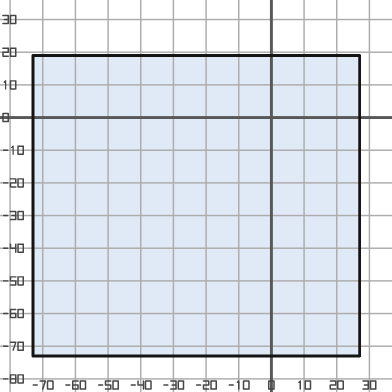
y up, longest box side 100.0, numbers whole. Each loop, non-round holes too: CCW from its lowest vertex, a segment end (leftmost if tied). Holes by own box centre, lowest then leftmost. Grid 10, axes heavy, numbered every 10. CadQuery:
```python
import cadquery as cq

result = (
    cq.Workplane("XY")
    .moveTo(-73.0, -73.0)
    .lineTo(27.0, -73.0)
    .lineTo(27.0, 19.0)
    .lineTo(-73.0, 19.0)
    .close()
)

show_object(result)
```